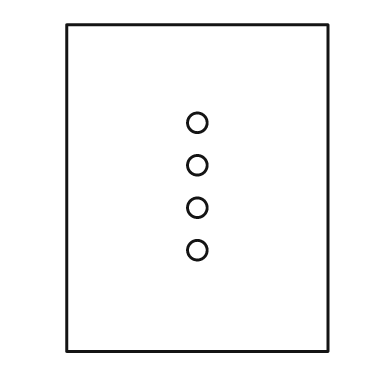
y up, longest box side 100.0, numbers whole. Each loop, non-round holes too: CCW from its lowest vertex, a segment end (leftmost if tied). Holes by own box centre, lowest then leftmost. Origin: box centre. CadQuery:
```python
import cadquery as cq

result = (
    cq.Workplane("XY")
    .moveTo(-40.0, -50.0)
    .lineTo(40.0, -50.0)
    .lineTo(40.0, 50.0)
    .lineTo(-40.0, 50.0)
    .close()
    .moveTo(0.0, -19.0)
    .circle(3.0)
    .moveTo(0.0, -6.0)
    .circle(3.0)
    .moveTo(0.0, 7.0)
    .circle(3.0)
    .moveTo(0.0, 20.0)
    .circle(3.0)
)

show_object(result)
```